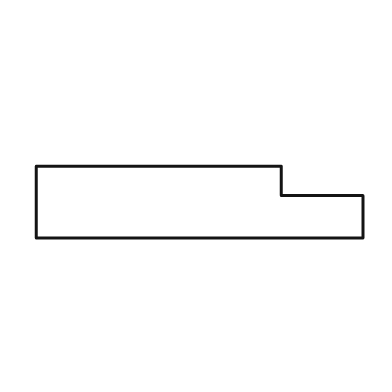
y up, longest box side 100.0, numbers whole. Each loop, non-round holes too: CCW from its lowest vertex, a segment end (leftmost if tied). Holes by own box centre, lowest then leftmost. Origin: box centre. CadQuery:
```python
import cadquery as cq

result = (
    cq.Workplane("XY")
    .moveTo(-50.0, -11.0)
    .lineTo(50.0, -11.0)
    .lineTo(50.0, 2.0)
    .lineTo(25.0, 2.0)
    .lineTo(25.0, 11.0)
    .lineTo(-50.0, 11.0)
    .close()
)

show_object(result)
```